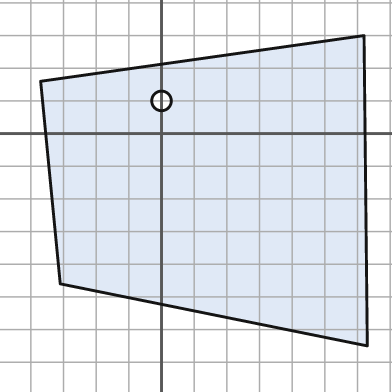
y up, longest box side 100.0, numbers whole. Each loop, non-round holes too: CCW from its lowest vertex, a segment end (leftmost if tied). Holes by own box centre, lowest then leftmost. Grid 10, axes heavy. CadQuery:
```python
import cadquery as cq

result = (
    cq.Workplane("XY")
    .moveTo(63.0, -65.0)
    .lineTo(62.0, 30.0)
    .lineTo(-37.0, 16.0)
    .lineTo(-31.0, -46.0)
    .close()
    .moveTo(0.0, 10.0)
    .circle(3.0)
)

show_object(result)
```